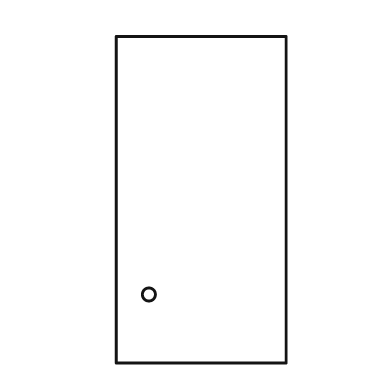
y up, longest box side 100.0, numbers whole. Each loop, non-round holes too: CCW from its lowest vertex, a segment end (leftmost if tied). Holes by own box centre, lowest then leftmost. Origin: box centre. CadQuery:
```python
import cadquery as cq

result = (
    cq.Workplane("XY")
    .moveTo(-26.0, -50.0)
    .lineTo(26.0, -50.0)
    .lineTo(26.0, 50.0)
    .lineTo(-26.0, 50.0)
    .close()
    .moveTo(-16.0, -29.0)
    .circle(2.0)
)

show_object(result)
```